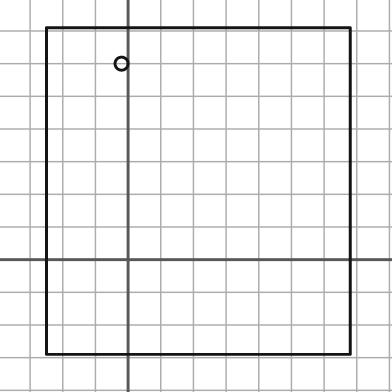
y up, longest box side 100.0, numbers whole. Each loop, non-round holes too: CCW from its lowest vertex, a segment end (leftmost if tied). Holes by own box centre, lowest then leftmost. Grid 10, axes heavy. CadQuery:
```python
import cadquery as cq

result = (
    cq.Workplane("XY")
    .moveTo(-25.0, -29.0)
    .lineTo(68.0, -29.0)
    .lineTo(68.0, 71.0)
    .lineTo(-25.0, 71.0)
    .close()
    .moveTo(-2.0, 60.0)
    .circle(2.0)
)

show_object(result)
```